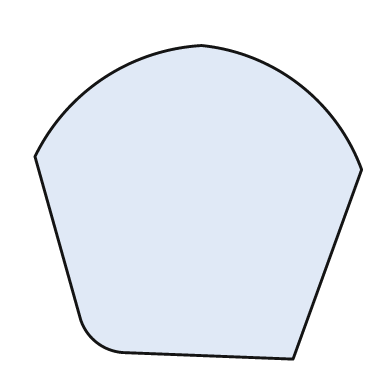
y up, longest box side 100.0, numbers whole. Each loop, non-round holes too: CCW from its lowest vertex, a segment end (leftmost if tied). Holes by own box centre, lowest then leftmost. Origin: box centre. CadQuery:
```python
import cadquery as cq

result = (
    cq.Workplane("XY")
    .moveTo(29.0, -48.0)
    .lineTo(50.0, 10.0)
    .threePointArc((31.0, 36.0), (1.0, 48.0))
    .threePointArc((-29.0, 38.0), (-50.0, 14.0))
    .lineTo(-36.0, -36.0)
    .threePointArc((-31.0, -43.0), (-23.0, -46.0))
    .close()
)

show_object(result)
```